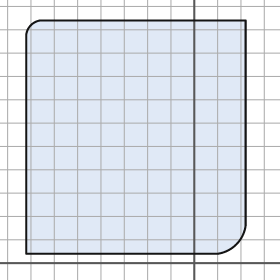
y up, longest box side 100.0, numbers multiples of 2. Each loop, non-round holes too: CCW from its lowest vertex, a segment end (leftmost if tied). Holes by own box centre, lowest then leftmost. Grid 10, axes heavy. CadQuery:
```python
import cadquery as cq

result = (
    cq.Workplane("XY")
    .moveTo(-72.0, 4.0)
    .lineTo(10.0, 4.0)
    .threePointArc((18.0, 8.0), (22.0, 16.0))
    .lineTo(22.0, 104.0)
    .lineTo(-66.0, 104.0)
    .threePointArc((-70.0, 102.0), (-72.0, 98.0))
    .close()
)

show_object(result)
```